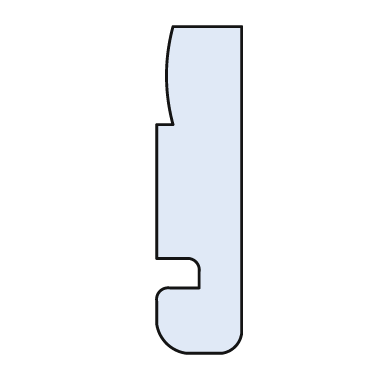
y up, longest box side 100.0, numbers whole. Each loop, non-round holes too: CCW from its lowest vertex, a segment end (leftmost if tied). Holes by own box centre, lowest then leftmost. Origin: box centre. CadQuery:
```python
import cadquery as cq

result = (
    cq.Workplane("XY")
    .moveTo(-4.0, -50.0)
    .lineTo(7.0, -50.0)
    .threePointArc((11.0, -48.0), (13.0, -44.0))
    .lineTo(13.0, 50.0)
    .lineTo(-8.0, 50.0)
    .threePointArc((-10.0, 35.0), (-8.0, 20.0))
    .lineTo(-13.0, 20.0)
    .lineTo(-13.0, -21.0)
    .lineTo(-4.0, -21.0)
    .threePointArc((-1.0, -22.0), (0.0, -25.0))
    .lineTo(0.0, -30.0)
    .lineTo(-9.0, -30.0)
    .threePointArc((-12.0, -31.0), (-13.0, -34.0))
    .lineTo(-13.0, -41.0)
    .threePointArc((-10.0, -47.0), (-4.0, -50.0))
    .close()
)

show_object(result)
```